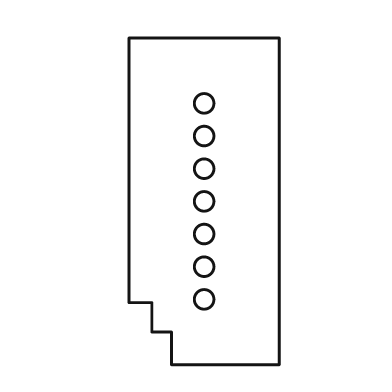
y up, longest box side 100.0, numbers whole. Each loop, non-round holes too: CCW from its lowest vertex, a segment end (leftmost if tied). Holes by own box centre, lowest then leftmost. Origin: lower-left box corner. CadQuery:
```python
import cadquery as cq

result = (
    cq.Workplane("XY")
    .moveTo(13.0, 0.0)
    .lineTo(46.0, 0.0)
    .lineTo(46.0, 100.0)
    .lineTo(0.0, 100.0)
    .lineTo(0.0, 19.0)
    .lineTo(7.0, 19.0)
    .lineTo(7.0, 10.0)
    .lineTo(13.0, 10.0)
    .close()
    .moveTo(23.0, 20.0)
    .circle(3.0)
    .moveTo(23.0, 30.0)
    .circle(3.0)
    .moveTo(23.0, 40.0)
    .circle(3.0)
    .moveTo(23.0, 50.0)
    .circle(3.0)
    .moveTo(23.0, 60.0)
    .circle(3.0)
    .moveTo(23.0, 70.0)
    .circle(3.0)
    .moveTo(23.0, 80.0)
    .circle(3.0)
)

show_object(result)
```